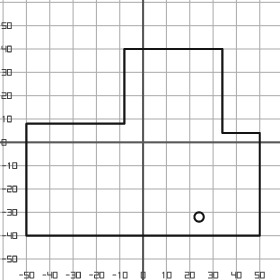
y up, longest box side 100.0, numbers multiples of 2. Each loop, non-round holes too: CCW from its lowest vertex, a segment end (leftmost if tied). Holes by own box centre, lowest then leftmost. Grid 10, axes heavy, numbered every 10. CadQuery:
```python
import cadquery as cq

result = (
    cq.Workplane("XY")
    .moveTo(-50.0, -40.0)
    .lineTo(50.0, -40.0)
    .lineTo(50.0, 4.0)
    .lineTo(34.0, 4.0)
    .lineTo(34.0, 40.0)
    .lineTo(-8.0, 40.0)
    .lineTo(-8.0, 8.0)
    .lineTo(-50.0, 8.0)
    .close()
    .moveTo(24.0, -32.0)
    .circle(2.0)
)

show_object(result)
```